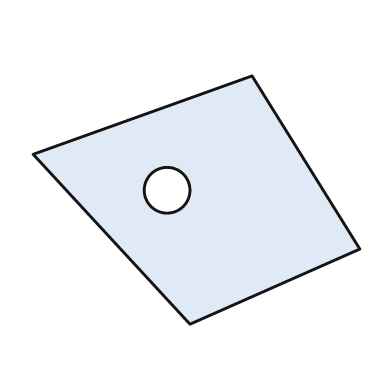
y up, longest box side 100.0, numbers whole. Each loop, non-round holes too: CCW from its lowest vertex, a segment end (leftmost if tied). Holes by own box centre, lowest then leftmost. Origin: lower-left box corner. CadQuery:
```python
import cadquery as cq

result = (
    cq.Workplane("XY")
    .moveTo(48.0, 0.0)
    .lineTo(100.0, 23.0)
    .lineTo(67.0, 76.0)
    .lineTo(0.0, 52.0)
    .close()
    .moveTo(41.0, 41.0)
    .circle(7.0)
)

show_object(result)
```